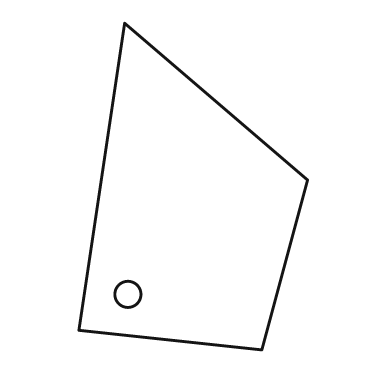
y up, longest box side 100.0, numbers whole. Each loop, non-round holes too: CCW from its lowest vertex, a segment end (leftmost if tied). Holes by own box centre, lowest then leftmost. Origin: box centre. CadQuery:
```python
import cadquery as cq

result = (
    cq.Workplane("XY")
    .moveTo(21.0, -50.0)
    .lineTo(35.0, 2.0)
    .lineTo(-21.0, 50.0)
    .lineTo(-35.0, -44.0)
    .close()
    .moveTo(-20.0, -33.0)
    .circle(4.0)
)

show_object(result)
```